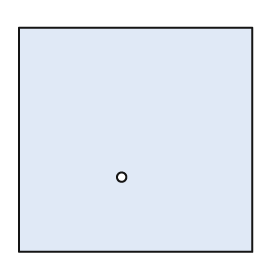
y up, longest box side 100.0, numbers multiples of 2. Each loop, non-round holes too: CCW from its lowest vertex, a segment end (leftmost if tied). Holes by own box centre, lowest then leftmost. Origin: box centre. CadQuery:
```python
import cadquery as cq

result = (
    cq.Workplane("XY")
    .moveTo(-50.0, -48.0)
    .lineTo(50.0, -48.0)
    .lineTo(50.0, 48.0)
    .lineTo(-50.0, 48.0)
    .close()
    .moveTo(-6.0, -16.0)
    .circle(2.0)
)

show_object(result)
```